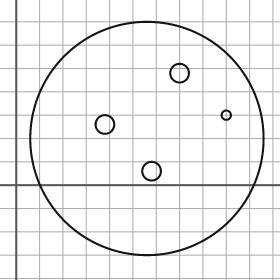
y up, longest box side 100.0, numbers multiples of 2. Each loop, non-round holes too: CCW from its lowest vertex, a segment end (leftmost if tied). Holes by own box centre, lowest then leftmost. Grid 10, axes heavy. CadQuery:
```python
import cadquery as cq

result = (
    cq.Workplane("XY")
    .moveTo(56.0, 20.0)
    .circle(50.0)
    .moveTo(58.0, 6.0)
    .circle(4.0)
    .moveTo(38.0, 26.0)
    .circle(4.0)
    .moveTo(90.0, 30.0)
    .circle(2.0)
    .moveTo(70.0, 48.0)
    .circle(4.0)
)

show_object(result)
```